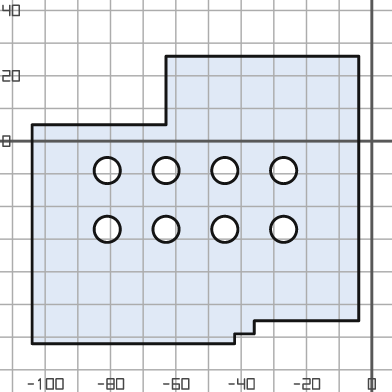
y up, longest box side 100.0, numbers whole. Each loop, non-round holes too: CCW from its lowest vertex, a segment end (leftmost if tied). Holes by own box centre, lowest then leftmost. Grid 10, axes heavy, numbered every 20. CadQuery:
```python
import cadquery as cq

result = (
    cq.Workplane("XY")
    .moveTo(-104.0, -62.0)
    .lineTo(-42.0, -62.0)
    .lineTo(-42.0, -59.0)
    .lineTo(-36.0, -59.0)
    .lineTo(-36.0, -55.0)
    .lineTo(-4.0, -55.0)
    .lineTo(-4.0, 26.0)
    .lineTo(-63.0, 26.0)
    .lineTo(-63.0, 5.0)
    .lineTo(-104.0, 5.0)
    .close()
    .moveTo(-81.0, -27.0)
    .circle(4.0)
    .moveTo(-63.0, -27.0)
    .circle(4.0)
    .moveTo(-45.0, -27.0)
    .circle(4.0)
    .moveTo(-27.0, -27.0)
    .circle(4.0)
    .moveTo(-81.0, -9.0)
    .circle(4.0)
    .moveTo(-63.0, -9.0)
    .circle(4.0)
    .moveTo(-45.0, -9.0)
    .circle(4.0)
    .moveTo(-27.0, -9.0)
    .circle(4.0)
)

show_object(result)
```